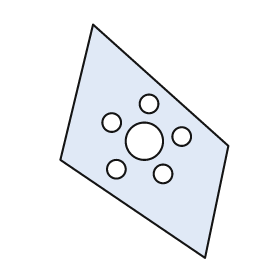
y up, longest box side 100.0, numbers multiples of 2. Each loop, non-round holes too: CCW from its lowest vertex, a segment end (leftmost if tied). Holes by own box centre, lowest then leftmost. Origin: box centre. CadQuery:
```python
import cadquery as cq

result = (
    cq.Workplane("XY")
    .moveTo(26.0, -50.0)
    .lineTo(36.0, -2.0)
    .lineTo(-22.0, 50.0)
    .lineTo(-36.0, -8.0)
    .close()
    .moveTo(8.0, -14.0)
    .circle(4.0)
    .moveTo(-12.0, -12.0)
    .circle(4.0)
    .moveTo(0.0, 0.0)
    .circle(8.0)
    .moveTo(16.0, 2.0)
    .circle(4.0)
    .moveTo(-14.0, 8.0)
    .circle(4.0)
    .moveTo(2.0, 16.0)
    .circle(4.0)
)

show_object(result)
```